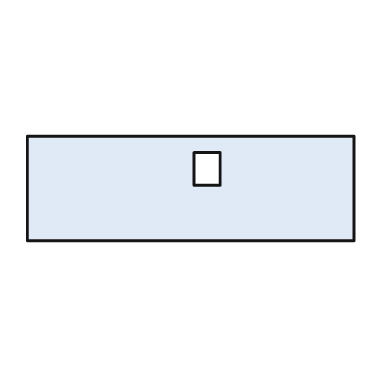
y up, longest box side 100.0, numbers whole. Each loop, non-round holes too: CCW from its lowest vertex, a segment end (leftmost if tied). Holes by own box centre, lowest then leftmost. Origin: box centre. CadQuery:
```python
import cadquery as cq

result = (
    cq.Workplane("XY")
    .moveTo(-50.0, -16.0)
    .lineTo(50.0, -16.0)
    .lineTo(50.0, 16.0)
    .lineTo(-50.0, 16.0)
    .close()
    .moveTo(1.0, 1.0)
    .lineTo(9.0, 1.0)
    .lineTo(9.0, 11.0)
    .lineTo(1.0, 11.0)
    .close()
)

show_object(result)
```